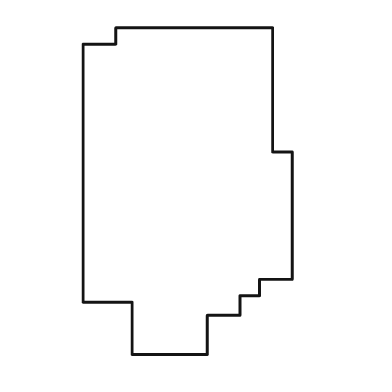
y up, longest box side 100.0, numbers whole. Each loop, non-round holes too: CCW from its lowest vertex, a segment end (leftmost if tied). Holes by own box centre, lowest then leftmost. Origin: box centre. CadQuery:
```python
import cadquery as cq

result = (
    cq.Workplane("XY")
    .moveTo(-17.0, -50.0)
    .lineTo(6.0, -50.0)
    .lineTo(6.0, -38.0)
    .lineTo(16.0, -38.0)
    .lineTo(16.0, -32.0)
    .lineTo(22.0, -32.0)
    .lineTo(22.0, -27.0)
    .lineTo(32.0, -27.0)
    .lineTo(32.0, 12.0)
    .lineTo(26.0, 12.0)
    .lineTo(26.0, 50.0)
    .lineTo(-22.0, 50.0)
    .lineTo(-22.0, 45.0)
    .lineTo(-32.0, 45.0)
    .lineTo(-32.0, -34.0)
    .lineTo(-17.0, -34.0)
    .close()
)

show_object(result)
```